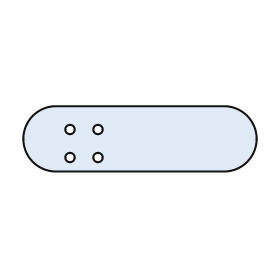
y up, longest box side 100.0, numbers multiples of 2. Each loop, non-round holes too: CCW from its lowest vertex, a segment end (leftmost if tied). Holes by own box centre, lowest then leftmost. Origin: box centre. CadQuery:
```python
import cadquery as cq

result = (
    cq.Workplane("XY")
    .moveTo(-36.0, -14.0)
    .lineTo(36.0, -14.0)
    .threePointArc((50.0, 0.0), (36.0, 14.0))
    .lineTo(-36.0, 14.0)
    .threePointArc((-50.0, 0.0), (-36.0, -14.0))
    .close()
    .moveTo(-30.0, -8.0)
    .circle(2.0)
    .moveTo(-18.0, -8.0)
    .circle(2.0)
    .moveTo(-30.0, 4.0)
    .circle(2.0)
    .moveTo(-18.0, 4.0)
    .circle(2.0)
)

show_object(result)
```